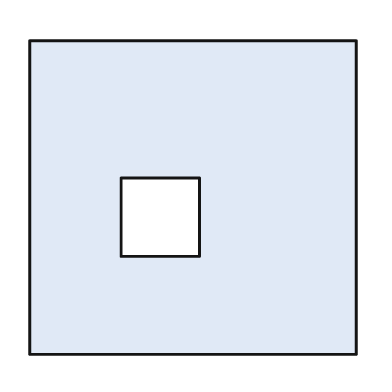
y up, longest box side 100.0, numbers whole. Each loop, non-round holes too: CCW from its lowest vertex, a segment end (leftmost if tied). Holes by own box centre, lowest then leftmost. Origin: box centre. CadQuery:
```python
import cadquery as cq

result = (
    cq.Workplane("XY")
    .moveTo(-50.0, -48.0)
    .lineTo(50.0, -48.0)
    .lineTo(50.0, 48.0)
    .lineTo(-50.0, 48.0)
    .close()
    .moveTo(-22.0, -18.0)
    .lineTo(2.0, -18.0)
    .lineTo(2.0, 6.0)
    .lineTo(-22.0, 6.0)
    .close()
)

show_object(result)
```